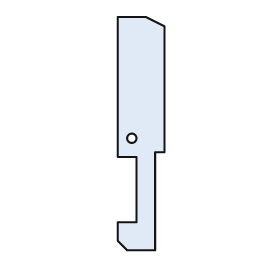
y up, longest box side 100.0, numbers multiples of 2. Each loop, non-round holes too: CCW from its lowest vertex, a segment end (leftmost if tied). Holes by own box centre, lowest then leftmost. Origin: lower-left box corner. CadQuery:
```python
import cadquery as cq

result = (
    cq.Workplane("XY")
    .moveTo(4.0, 0.0)
    .lineTo(16.0, 0.0)
    .lineTo(16.0, 42.0)
    .lineTo(20.0, 42.0)
    .lineTo(20.0, 96.0)
    .lineTo(12.0, 100.0)
    .lineTo(0.0, 100.0)
    .lineTo(0.0, 40.0)
    .lineTo(8.0, 40.0)
    .lineTo(8.0, 12.0)
    .lineTo(0.0, 12.0)
    .lineTo(0.0, 4.0)
    .close()
    .moveTo(6.0, 48.0)
    .circle(2.0)
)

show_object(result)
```